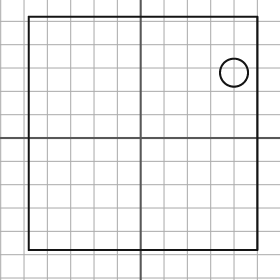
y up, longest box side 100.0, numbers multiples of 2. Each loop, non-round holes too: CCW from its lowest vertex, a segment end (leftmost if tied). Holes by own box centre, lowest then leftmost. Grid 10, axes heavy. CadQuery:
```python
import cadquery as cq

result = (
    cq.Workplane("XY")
    .moveTo(-48.0, -48.0)
    .lineTo(50.0, -48.0)
    .lineTo(50.0, 52.0)
    .lineTo(-48.0, 52.0)
    .close()
    .moveTo(40.0, 28.0)
    .circle(6.0)
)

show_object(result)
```